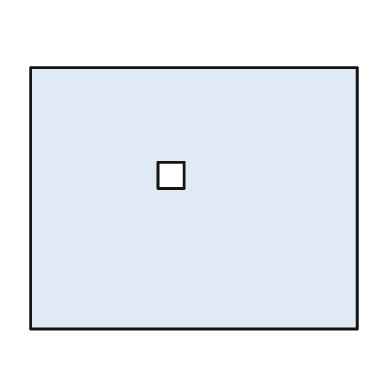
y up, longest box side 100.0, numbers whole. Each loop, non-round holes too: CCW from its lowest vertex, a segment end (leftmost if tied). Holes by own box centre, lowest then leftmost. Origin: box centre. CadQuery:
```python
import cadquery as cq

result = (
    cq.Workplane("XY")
    .moveTo(-50.0, -40.0)
    .lineTo(50.0, -40.0)
    .lineTo(50.0, 40.0)
    .lineTo(-50.0, 40.0)
    .close()
    .moveTo(-11.0, 3.0)
    .lineTo(-3.0, 3.0)
    .lineTo(-3.0, 11.0)
    .lineTo(-11.0, 11.0)
    .close()
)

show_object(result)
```